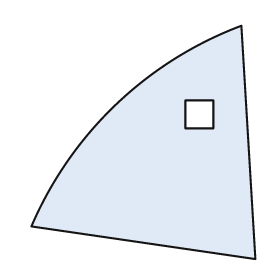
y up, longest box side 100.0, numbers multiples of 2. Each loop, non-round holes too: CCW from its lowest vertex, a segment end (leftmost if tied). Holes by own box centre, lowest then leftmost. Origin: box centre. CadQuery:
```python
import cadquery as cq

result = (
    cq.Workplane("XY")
    .moveTo(48.0, -50.0)
    .lineTo(42.0, 50.0)
    .threePointArc((-12.0, 16.0), (-48.0, -36.0))
    .close()
    .moveTo(18.0, 6.0)
    .lineTo(30.0, 6.0)
    .lineTo(30.0, 18.0)
    .lineTo(18.0, 18.0)
    .close()
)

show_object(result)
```